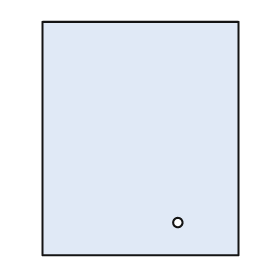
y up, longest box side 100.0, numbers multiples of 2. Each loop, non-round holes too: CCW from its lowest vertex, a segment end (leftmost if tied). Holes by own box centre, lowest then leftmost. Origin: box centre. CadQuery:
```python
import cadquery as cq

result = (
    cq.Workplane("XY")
    .moveTo(-42.0, -50.0)
    .lineTo(42.0, -50.0)
    .lineTo(42.0, 50.0)
    .lineTo(-42.0, 50.0)
    .close()
    .moveTo(16.0, -36.0)
    .circle(2.0)
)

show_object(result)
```